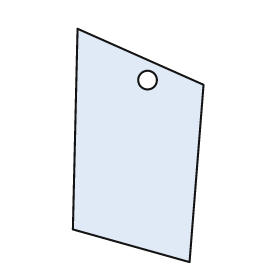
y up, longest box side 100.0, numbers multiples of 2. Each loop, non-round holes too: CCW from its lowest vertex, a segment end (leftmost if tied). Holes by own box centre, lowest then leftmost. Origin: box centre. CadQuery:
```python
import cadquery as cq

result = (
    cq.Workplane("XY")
    .moveTo(22.0, -50.0)
    .lineTo(28.0, 26.0)
    .lineTo(-26.0, 50.0)
    .lineTo(-28.0, -36.0)
    .close()
    .moveTo(4.0, 28.0)
    .circle(4.0)
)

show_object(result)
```